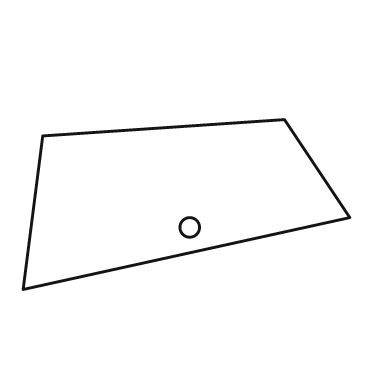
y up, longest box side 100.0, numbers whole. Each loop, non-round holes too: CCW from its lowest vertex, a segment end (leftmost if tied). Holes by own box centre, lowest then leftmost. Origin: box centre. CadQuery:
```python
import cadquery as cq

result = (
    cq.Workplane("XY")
    .moveTo(-50.0, -26.0)
    .lineTo(50.0, -4.0)
    .lineTo(30.0, 26.0)
    .lineTo(-44.0, 21.0)
    .close()
    .moveTo(1.0, -7.0)
    .circle(3.0)
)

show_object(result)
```